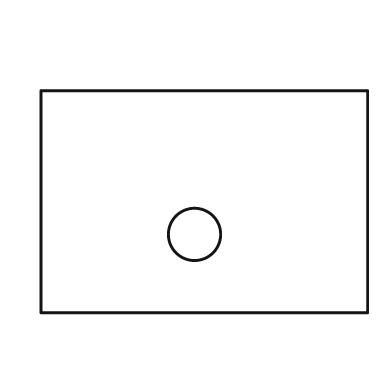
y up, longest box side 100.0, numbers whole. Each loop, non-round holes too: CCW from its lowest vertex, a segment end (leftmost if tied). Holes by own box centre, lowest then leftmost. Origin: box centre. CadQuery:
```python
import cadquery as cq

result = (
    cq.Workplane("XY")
    .moveTo(-50.0, -34.0)
    .lineTo(50.0, -34.0)
    .lineTo(50.0, 34.0)
    .lineTo(-50.0, 34.0)
    .close()
    .moveTo(-3.0, -10.0)
    .circle(8.0)
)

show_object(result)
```